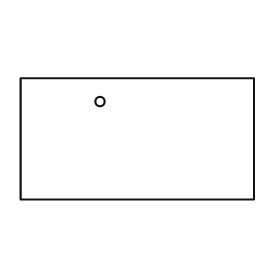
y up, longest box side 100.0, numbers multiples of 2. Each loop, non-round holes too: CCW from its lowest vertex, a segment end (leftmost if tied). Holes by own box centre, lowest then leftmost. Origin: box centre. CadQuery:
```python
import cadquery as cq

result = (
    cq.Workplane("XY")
    .moveTo(-50.0, -26.0)
    .lineTo(50.0, -26.0)
    .lineTo(50.0, 26.0)
    .lineTo(-50.0, 26.0)
    .close()
    .moveTo(-16.0, 16.0)
    .circle(2.0)
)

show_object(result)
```